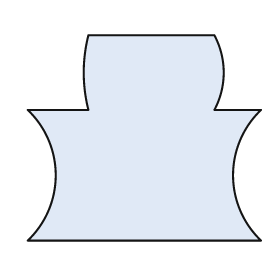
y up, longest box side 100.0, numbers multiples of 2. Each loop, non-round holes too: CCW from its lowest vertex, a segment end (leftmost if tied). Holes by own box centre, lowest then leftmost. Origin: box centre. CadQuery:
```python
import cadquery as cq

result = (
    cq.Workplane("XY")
    .moveTo(-50.0, -44.0)
    .lineTo(50.0, -44.0)
    .threePointArc((38.0, -16.0), (50.0, 12.0))
    .lineTo(30.0, 12.0)
    .threePointArc((34.0, 28.0), (30.0, 44.0))
    .lineTo(-24.0, 44.0)
    .threePointArc((-26.0, 28.0), (-24.0, 12.0))
    .lineTo(-50.0, 12.0)
    .threePointArc((-38.0, -16.0), (-50.0, -44.0))
    .close()
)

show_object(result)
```